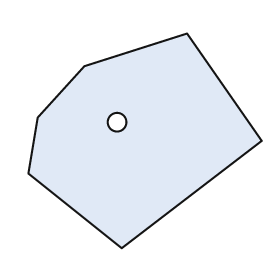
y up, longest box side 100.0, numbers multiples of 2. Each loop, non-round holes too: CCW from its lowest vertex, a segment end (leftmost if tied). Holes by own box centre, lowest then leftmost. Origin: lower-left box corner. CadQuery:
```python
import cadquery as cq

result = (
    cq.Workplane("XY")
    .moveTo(40.0, 0.0)
    .lineTo(100.0, 46.0)
    .lineTo(68.0, 92.0)
    .lineTo(24.0, 78.0)
    .lineTo(4.0, 56.0)
    .lineTo(0.0, 32.0)
    .close()
    .moveTo(38.0, 54.0)
    .circle(4.0)
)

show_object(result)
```